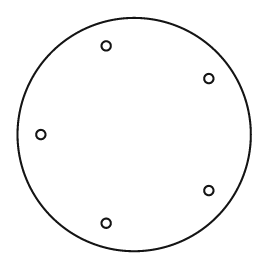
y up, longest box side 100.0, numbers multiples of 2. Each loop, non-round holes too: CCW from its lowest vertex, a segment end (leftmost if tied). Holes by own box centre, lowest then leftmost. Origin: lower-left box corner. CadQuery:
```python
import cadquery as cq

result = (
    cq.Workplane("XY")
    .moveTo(50.0, 50.0)
    .circle(50.0)
    .moveTo(38.0, 12.0)
    .circle(2.0)
    .moveTo(82.0, 26.0)
    .circle(2.0)
    .moveTo(10.0, 50.0)
    .circle(2.0)
    .moveTo(82.0, 74.0)
    .circle(2.0)
    .moveTo(38.0, 88.0)
    .circle(2.0)
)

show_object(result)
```